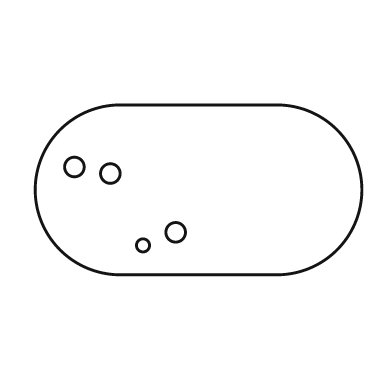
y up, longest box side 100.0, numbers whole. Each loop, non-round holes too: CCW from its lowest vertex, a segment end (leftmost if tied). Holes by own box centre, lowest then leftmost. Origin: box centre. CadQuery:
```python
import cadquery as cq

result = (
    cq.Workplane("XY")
    .moveTo(-24.0, -26.0)
    .lineTo(24.0, -26.0)
    .threePointArc((50.0, 0.0), (24.0, 26.0))
    .lineTo(-24.0, 26.0)
    .threePointArc((-50.0, 0.0), (-24.0, -26.0))
    .close()
    .moveTo(-17.0, -17.0)
    .circle(2.0)
    .moveTo(-7.0, -13.0)
    .circle(3.0)
    .moveTo(-27.0, 5.0)
    .circle(3.0)
    .moveTo(-38.0, 7.0)
    .circle(3.0)
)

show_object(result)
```